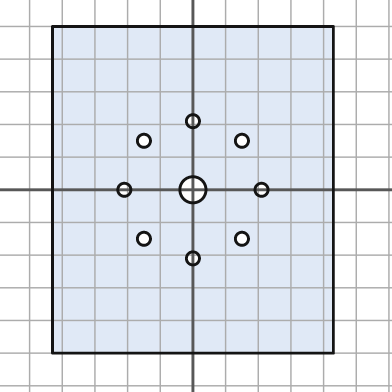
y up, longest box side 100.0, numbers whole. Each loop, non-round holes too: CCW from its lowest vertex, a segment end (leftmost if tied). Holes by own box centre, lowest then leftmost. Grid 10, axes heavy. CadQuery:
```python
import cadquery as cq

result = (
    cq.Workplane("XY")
    .moveTo(-43.0, -50.0)
    .lineTo(43.0, -50.0)
    .lineTo(43.0, 50.0)
    .lineTo(-43.0, 50.0)
    .close()
    .moveTo(0.0, -21.0)
    .circle(2.0)
    .moveTo(-15.0, -15.0)
    .circle(2.0)
    .moveTo(15.0, -15.0)
    .circle(2.0)
    .moveTo(-21.0, 0.0)
    .circle(2.0)
    .moveTo(0.0, 0.0)
    .circle(4.0)
    .moveTo(21.0, 0.0)
    .circle(2.0)
    .moveTo(-15.0, 15.0)
    .circle(2.0)
    .moveTo(15.0, 15.0)
    .circle(2.0)
    .moveTo(0.0, 21.0)
    .circle(2.0)
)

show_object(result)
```